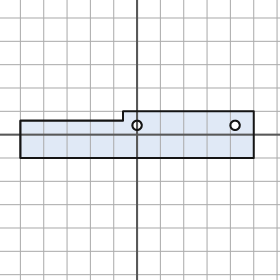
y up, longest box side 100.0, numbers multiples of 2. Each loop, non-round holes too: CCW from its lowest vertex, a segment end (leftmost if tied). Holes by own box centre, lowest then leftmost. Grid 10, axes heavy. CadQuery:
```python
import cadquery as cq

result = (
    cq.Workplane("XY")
    .moveTo(-50.0, -10.0)
    .lineTo(50.0, -10.0)
    .lineTo(50.0, 10.0)
    .lineTo(-6.0, 10.0)
    .lineTo(-6.0, 6.0)
    .lineTo(-50.0, 6.0)
    .close()
    .moveTo(0.0, 4.0)
    .circle(2.0)
    .moveTo(42.0, 4.0)
    .circle(2.0)
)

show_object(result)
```